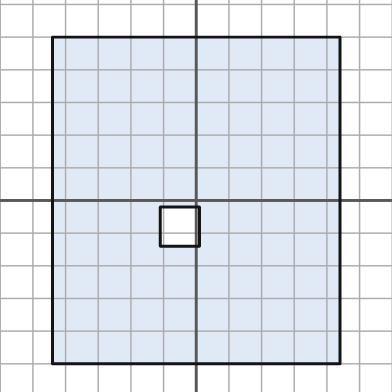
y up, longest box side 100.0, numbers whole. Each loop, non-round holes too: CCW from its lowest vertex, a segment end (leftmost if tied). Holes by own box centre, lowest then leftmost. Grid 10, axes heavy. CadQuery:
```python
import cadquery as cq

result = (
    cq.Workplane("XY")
    .moveTo(-44.0, -50.0)
    .lineTo(44.0, -50.0)
    .lineTo(44.0, 50.0)
    .lineTo(-44.0, 50.0)
    .close()
    .moveTo(-11.0, -14.0)
    .lineTo(1.0, -14.0)
    .lineTo(1.0, -2.0)
    .lineTo(-11.0, -2.0)
    .close()
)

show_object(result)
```